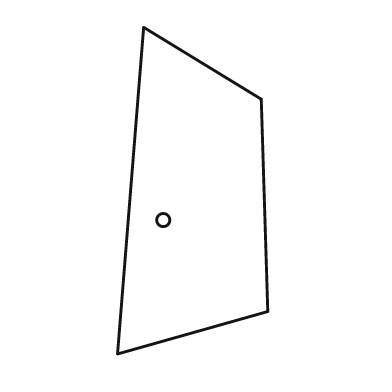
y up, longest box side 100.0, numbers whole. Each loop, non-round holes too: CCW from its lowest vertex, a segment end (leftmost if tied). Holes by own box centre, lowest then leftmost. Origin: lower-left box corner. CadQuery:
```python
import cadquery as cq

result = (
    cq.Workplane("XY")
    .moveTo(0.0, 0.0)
    .lineTo(46.0, 13.0)
    .lineTo(44.0, 78.0)
    .lineTo(8.0, 100.0)
    .close()
    .moveTo(14.0, 41.0)
    .circle(2.0)
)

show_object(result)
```